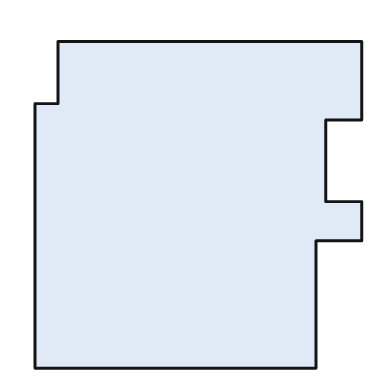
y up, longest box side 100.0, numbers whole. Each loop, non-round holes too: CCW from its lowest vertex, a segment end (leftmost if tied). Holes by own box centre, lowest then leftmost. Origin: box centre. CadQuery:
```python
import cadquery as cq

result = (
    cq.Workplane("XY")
    .moveTo(-50.0, -50.0)
    .lineTo(36.0, -50.0)
    .lineTo(36.0, -11.0)
    .lineTo(50.0, -11.0)
    .lineTo(50.0, 1.0)
    .lineTo(39.0, 1.0)
    .lineTo(39.0, 26.0)
    .lineTo(50.0, 26.0)
    .lineTo(50.0, 50.0)
    .lineTo(-43.0, 50.0)
    .lineTo(-43.0, 31.0)
    .lineTo(-50.0, 31.0)
    .close()
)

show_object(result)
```